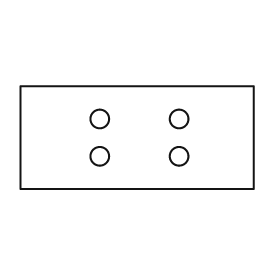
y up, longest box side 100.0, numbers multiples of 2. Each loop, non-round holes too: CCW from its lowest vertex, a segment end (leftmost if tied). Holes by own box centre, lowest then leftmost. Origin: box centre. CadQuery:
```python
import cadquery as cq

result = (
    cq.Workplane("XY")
    .moveTo(-50.0, -22.0)
    .lineTo(50.0, -22.0)
    .lineTo(50.0, 22.0)
    .lineTo(-50.0, 22.0)
    .close()
    .moveTo(-16.0, -8.0)
    .circle(4.0)
    .moveTo(18.0, -8.0)
    .circle(4.0)
    .moveTo(-16.0, 8.0)
    .circle(4.0)
    .moveTo(18.0, 8.0)
    .circle(4.0)
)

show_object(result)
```